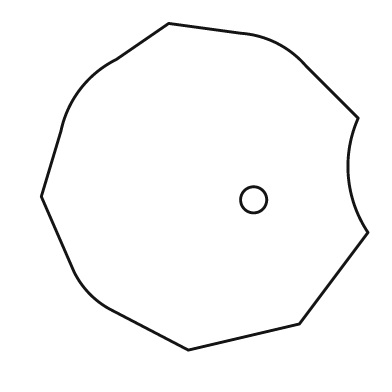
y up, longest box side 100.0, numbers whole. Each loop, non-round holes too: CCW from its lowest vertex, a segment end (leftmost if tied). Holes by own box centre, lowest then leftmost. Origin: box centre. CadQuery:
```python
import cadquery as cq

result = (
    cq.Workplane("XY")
    .moveTo(-5.0, -50.0)
    .lineTo(29.0, -42.0)
    .lineTo(50.0, -14.0)
    .threePointArc((44.0, 3.0), (47.0, 21.0))
    .lineTo(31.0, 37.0)
    .threePointArc((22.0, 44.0), (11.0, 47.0))
    .lineTo(-11.0, 50.0)
    .lineTo(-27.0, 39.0)
    .threePointArc((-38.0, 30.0), (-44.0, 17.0))
    .lineTo(-50.0, -3.0)
    .lineTo(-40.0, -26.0)
    .threePointArc((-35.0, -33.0), (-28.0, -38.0))
    .close()
    .moveTo(15.0, -4.0)
    .circle(4.0)
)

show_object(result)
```